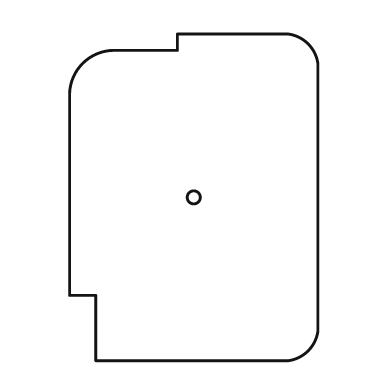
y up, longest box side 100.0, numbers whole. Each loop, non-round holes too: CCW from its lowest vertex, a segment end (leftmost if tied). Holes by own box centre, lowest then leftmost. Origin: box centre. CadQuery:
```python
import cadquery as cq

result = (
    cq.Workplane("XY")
    .moveTo(-30.0, -50.0)
    .lineTo(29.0, -50.0)
    .threePointArc((35.0, -47.0), (38.0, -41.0))
    .lineTo(38.0, 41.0)
    .threePointArc((35.0, 47.0), (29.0, 50.0))
    .lineTo(-5.0, 50.0)
    .lineTo(-5.0, 45.0)
    .lineTo(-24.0, 45.0)
    .threePointArc((-34.0, 41.0), (-38.0, 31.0))
    .lineTo(-38.0, -30.0)
    .lineTo(-30.0, -30.0)
    .close()
    .moveTo(0.0, 0.0)
    .circle(2.0)
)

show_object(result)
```